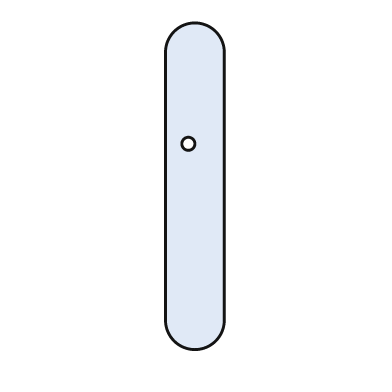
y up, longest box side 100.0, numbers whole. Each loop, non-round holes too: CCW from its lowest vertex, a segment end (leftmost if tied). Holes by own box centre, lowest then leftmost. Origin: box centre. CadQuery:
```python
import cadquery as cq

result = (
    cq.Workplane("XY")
    .moveTo(-9.0, -41.0)
    .threePointArc((0.0, -50.0), (9.0, -41.0))
    .lineTo(9.0, 41.0)
    .threePointArc((0.0, 50.0), (-9.0, 41.0))
    .close()
    .moveTo(-2.0, 13.0)
    .circle(2.0)
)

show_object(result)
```